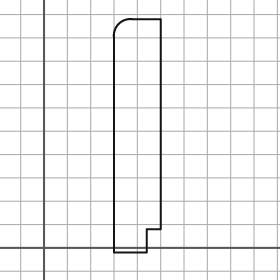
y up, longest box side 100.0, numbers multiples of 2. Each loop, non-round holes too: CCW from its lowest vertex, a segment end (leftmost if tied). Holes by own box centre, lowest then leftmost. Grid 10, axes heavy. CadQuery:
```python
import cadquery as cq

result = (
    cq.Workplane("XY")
    .moveTo(30.0, -2.0)
    .lineTo(44.0, -2.0)
    .lineTo(44.0, 8.0)
    .lineTo(50.0, 8.0)
    .lineTo(50.0, 98.0)
    .lineTo(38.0, 98.0)
    .threePointArc((32.0, 96.0), (30.0, 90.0))
    .close()
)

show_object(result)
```